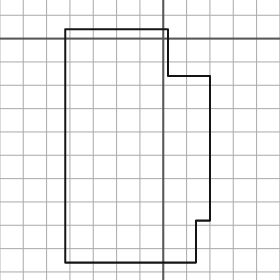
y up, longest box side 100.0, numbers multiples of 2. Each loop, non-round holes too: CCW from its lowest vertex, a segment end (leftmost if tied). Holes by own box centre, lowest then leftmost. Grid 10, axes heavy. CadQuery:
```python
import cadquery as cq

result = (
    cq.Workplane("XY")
    .moveTo(-42.0, -96.0)
    .lineTo(14.0, -96.0)
    .lineTo(14.0, -78.0)
    .lineTo(20.0, -78.0)
    .lineTo(20.0, -16.0)
    .lineTo(2.0, -16.0)
    .lineTo(2.0, 4.0)
    .lineTo(-42.0, 4.0)
    .close()
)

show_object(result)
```